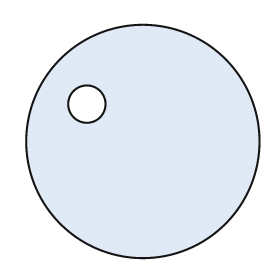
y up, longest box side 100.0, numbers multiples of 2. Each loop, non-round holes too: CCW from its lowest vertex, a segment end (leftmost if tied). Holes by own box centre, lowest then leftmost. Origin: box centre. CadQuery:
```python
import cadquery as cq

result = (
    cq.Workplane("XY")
    .moveTo(0.0, 0.0)
    .circle(50.0)
    .moveTo(-24.0, 16.0)
    .circle(8.0)
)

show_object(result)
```